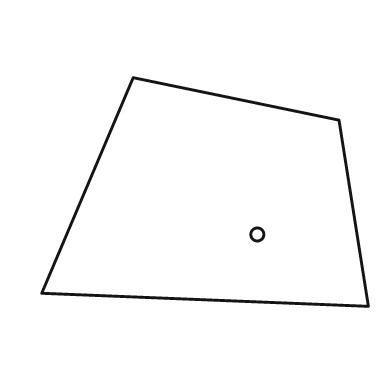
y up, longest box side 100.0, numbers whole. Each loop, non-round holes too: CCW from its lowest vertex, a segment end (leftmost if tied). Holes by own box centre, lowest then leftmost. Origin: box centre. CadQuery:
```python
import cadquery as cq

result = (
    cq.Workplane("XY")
    .moveTo(50.0, -35.0)
    .lineTo(41.0, 22.0)
    .lineTo(-22.0, 35.0)
    .lineTo(-50.0, -31.0)
    .close()
    .moveTo(16.0, -13.0)
    .circle(2.0)
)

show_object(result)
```